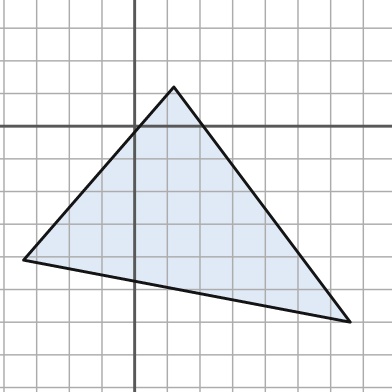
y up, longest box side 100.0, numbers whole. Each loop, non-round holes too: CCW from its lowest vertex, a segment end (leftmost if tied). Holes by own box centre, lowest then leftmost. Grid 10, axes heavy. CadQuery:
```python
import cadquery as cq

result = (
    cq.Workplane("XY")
    .moveTo(66.0, -60.0)
    .lineTo(12.0, 12.0)
    .lineTo(-34.0, -41.0)
    .close()
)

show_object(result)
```